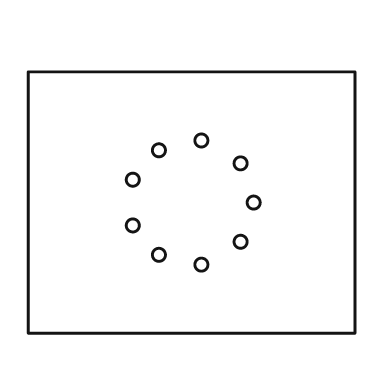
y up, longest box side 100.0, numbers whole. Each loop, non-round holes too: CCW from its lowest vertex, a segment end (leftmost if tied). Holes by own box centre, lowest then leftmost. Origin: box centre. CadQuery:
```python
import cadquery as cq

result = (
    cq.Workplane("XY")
    .moveTo(-50.0, -40.0)
    .lineTo(50.0, -40.0)
    .lineTo(50.0, 40.0)
    .lineTo(-50.0, 40.0)
    .close()
    .moveTo(3.0, -19.0)
    .circle(2.0)
    .moveTo(-10.0, -16.0)
    .circle(2.0)
    .moveTo(15.0, -12.0)
    .circle(2.0)
    .moveTo(-18.0, -7.0)
    .circle(2.0)
    .moveTo(19.0, 0.0)
    .circle(2.0)
    .moveTo(-18.0, 7.0)
    .circle(2.0)
    .moveTo(15.0, 12.0)
    .circle(2.0)
    .moveTo(-10.0, 16.0)
    .circle(2.0)
    .moveTo(3.0, 19.0)
    .circle(2.0)
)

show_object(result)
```